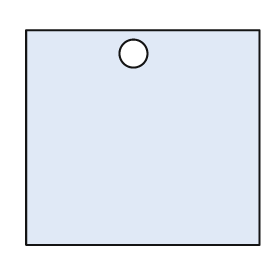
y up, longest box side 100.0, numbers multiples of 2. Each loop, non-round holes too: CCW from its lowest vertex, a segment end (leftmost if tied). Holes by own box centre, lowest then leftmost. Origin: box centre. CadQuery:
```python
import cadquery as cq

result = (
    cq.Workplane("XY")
    .moveTo(-50.0, -46.0)
    .lineTo(50.0, -46.0)
    .lineTo(50.0, 46.0)
    .lineTo(-50.0, 46.0)
    .close()
    .moveTo(-4.0, 36.0)
    .circle(6.0)
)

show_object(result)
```